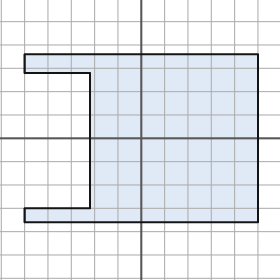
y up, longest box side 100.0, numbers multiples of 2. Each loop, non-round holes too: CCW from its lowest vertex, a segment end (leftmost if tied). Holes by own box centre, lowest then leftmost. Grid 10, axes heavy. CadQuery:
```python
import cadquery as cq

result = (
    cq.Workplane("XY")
    .moveTo(-50.0, -36.0)
    .lineTo(50.0, -36.0)
    .lineTo(50.0, 36.0)
    .lineTo(-50.0, 36.0)
    .lineTo(-50.0, 28.0)
    .lineTo(-22.0, 28.0)
    .lineTo(-22.0, -30.0)
    .lineTo(-50.0, -30.0)
    .close()
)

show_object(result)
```